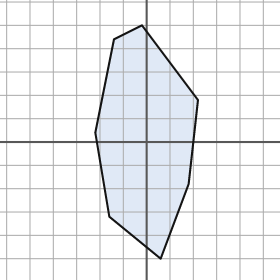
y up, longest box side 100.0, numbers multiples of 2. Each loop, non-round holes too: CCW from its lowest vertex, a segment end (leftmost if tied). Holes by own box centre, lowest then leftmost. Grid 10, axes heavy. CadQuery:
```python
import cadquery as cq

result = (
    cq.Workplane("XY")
    .moveTo(6.0, -50.0)
    .lineTo(18.0, -18.0)
    .lineTo(22.0, 18.0)
    .lineTo(-2.0, 50.0)
    .lineTo(-14.0, 44.0)
    .lineTo(-22.0, 4.0)
    .lineTo(-16.0, -32.0)
    .close()
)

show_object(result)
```